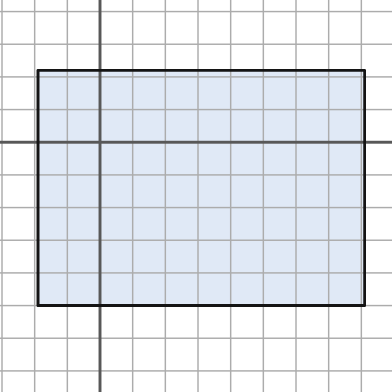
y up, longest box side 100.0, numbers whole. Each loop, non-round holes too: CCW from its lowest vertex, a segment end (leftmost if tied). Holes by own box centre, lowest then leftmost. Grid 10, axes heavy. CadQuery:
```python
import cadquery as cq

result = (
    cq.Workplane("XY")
    .moveTo(-19.0, -50.0)
    .lineTo(81.0, -50.0)
    .lineTo(81.0, 22.0)
    .lineTo(-19.0, 22.0)
    .close()
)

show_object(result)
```